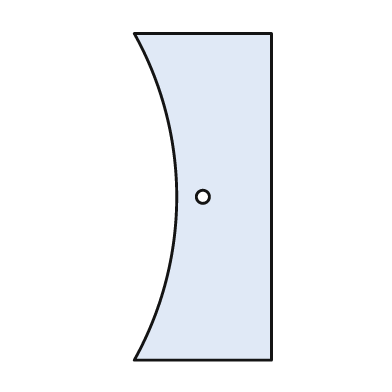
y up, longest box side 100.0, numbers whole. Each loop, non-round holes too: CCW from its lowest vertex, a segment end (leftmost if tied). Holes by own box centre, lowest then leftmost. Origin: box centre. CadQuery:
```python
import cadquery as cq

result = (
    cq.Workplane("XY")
    .moveTo(-21.0, -50.0)
    .lineTo(21.0, -50.0)
    .lineTo(21.0, 50.0)
    .lineTo(-21.0, 50.0)
    .threePointArc((-8.0, 0.0), (-21.0, -50.0))
    .close()
    .moveTo(0.0, 0.0)
    .circle(2.0)
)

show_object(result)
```